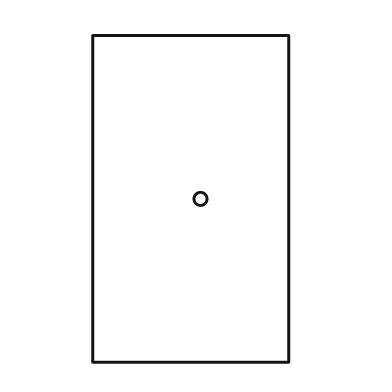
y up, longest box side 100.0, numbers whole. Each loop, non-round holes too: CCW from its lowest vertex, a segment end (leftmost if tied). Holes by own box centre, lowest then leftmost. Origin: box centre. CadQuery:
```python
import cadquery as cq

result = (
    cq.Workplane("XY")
    .moveTo(-30.0, -50.0)
    .lineTo(30.0, -50.0)
    .lineTo(30.0, 50.0)
    .lineTo(-30.0, 50.0)
    .close()
    .moveTo(3.0, 0.0)
    .circle(2.0)
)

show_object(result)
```